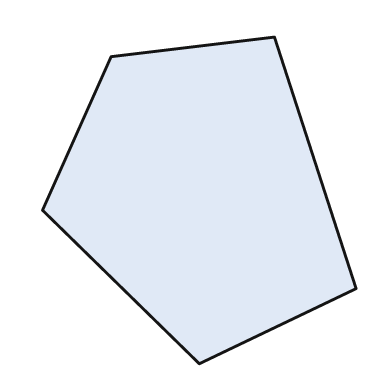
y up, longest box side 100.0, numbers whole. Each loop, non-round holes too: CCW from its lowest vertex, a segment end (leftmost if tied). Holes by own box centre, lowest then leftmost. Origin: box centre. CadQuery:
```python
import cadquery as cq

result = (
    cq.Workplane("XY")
    .moveTo(0.0, -50.0)
    .lineTo(48.0, -27.0)
    .lineTo(23.0, 50.0)
    .lineTo(-27.0, 44.0)
    .lineTo(-48.0, -3.0)
    .close()
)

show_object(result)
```